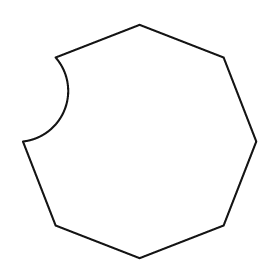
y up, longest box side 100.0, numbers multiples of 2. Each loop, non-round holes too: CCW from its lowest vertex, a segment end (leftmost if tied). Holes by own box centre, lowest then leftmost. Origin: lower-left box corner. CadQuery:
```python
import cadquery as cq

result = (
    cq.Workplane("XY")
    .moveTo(50.0, 0.0)
    .lineTo(86.0, 14.0)
    .lineTo(100.0, 50.0)
    .lineTo(86.0, 86.0)
    .lineTo(50.0, 100.0)
    .lineTo(14.0, 86.0)
    .threePointArc((18.0, 64.0), (0.0, 50.0))
    .lineTo(14.0, 14.0)
    .close()
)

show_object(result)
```